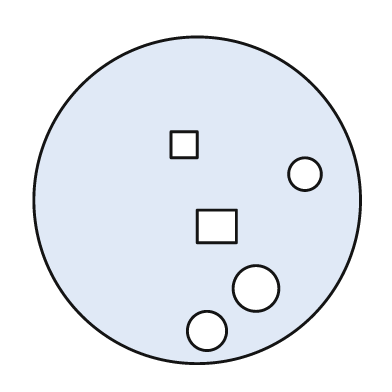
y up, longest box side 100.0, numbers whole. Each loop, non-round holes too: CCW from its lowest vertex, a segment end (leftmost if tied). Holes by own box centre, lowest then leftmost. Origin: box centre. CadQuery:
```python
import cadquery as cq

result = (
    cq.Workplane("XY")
    .moveTo(0.0, 0.0)
    .circle(50.0)
    .moveTo(3.0, -40.0)
    .circle(6.0)
    .moveTo(18.0, -27.0)
    .circle(7.0)
    .moveTo(0.0, -13.0)
    .lineTo(12.0, -13.0)
    .lineTo(12.0, -3.0)
    .lineTo(0.0, -3.0)
    .close()
    .moveTo(33.0, 8.0)
    .circle(5.0)
    .moveTo(-8.0, 13.0)
    .lineTo(0.0, 13.0)
    .lineTo(0.0, 21.0)
    .lineTo(-8.0, 21.0)
    .close()
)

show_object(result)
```